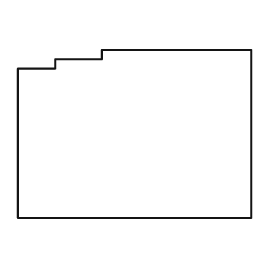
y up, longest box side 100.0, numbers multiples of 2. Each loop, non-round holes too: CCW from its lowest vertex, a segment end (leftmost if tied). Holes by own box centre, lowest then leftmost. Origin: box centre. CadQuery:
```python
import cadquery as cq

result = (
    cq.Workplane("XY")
    .moveTo(-50.0, -36.0)
    .lineTo(50.0, -36.0)
    .lineTo(50.0, 36.0)
    .lineTo(-14.0, 36.0)
    .lineTo(-14.0, 32.0)
    .lineTo(-34.0, 32.0)
    .lineTo(-34.0, 28.0)
    .lineTo(-50.0, 28.0)
    .close()
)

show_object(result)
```